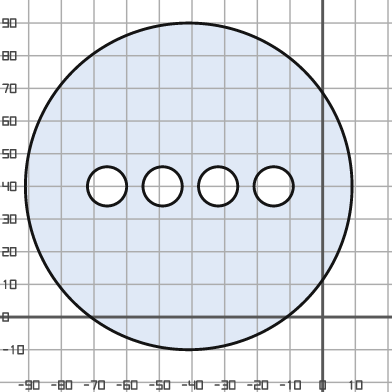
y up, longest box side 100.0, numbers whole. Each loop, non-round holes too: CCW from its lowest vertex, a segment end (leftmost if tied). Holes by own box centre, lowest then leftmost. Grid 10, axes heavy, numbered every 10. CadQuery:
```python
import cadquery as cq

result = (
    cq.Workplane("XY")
    .moveTo(-41.0, 40.0)
    .circle(50.0)
    .moveTo(-66.0, 40.0)
    .circle(6.0)
    .moveTo(-49.0, 40.0)
    .circle(6.0)
    .moveTo(-32.0, 40.0)
    .circle(6.0)
    .moveTo(-15.0, 40.0)
    .circle(6.0)
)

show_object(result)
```